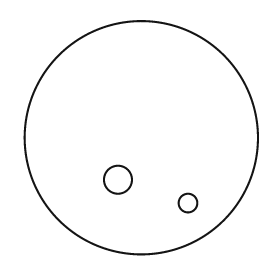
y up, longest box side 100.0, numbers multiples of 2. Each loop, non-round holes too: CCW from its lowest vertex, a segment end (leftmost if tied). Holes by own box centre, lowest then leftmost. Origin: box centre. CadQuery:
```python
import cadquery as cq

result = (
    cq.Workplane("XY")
    .moveTo(0.0, 0.0)
    .circle(50.0)
    .moveTo(20.0, -28.0)
    .circle(4.0)
    .moveTo(-10.0, -18.0)
    .circle(6.0)
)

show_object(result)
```